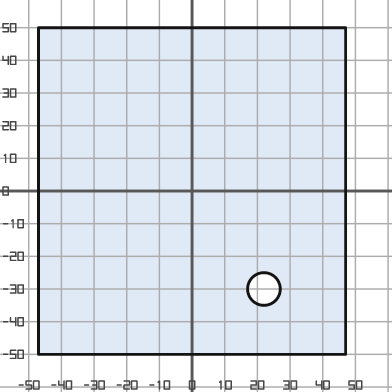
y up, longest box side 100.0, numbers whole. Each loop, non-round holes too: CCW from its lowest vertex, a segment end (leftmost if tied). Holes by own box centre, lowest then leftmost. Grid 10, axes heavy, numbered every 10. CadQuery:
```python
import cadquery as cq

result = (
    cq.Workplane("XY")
    .moveTo(-47.0, -50.0)
    .lineTo(47.0, -50.0)
    .lineTo(47.0, 50.0)
    .lineTo(-47.0, 50.0)
    .close()
    .moveTo(22.0, -30.0)
    .circle(5.0)
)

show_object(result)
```